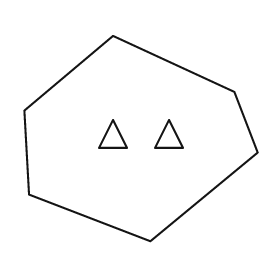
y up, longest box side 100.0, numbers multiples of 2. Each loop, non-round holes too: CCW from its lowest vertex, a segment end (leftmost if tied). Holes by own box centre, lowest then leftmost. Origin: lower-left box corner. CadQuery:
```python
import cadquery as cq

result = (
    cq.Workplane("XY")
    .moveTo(54.0, 0.0)
    .lineTo(100.0, 38.0)
    .lineTo(90.0, 64.0)
    .lineTo(38.0, 88.0)
    .lineTo(0.0, 56.0)
    .lineTo(2.0, 20.0)
    .close()
    .moveTo(32.0, 40.0)
    .lineTo(44.0, 40.0)
    .lineTo(38.0, 52.0)
    .close()
    .moveTo(56.0, 40.0)
    .lineTo(68.0, 40.0)
    .lineTo(62.0, 52.0)
    .close()
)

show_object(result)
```